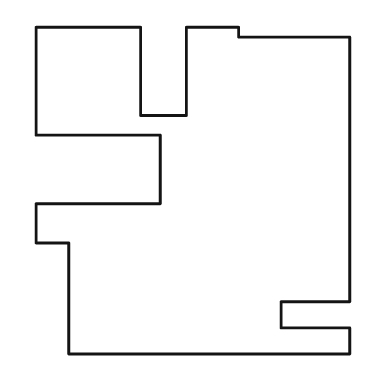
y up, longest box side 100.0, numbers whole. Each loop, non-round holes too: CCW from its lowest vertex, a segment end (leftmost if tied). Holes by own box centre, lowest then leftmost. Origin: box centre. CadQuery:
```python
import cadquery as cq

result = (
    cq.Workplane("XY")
    .moveTo(-38.0, -50.0)
    .lineTo(48.0, -50.0)
    .lineTo(48.0, -42.0)
    .lineTo(27.0, -42.0)
    .lineTo(27.0, -34.0)
    .lineTo(48.0, -34.0)
    .lineTo(48.0, 47.0)
    .lineTo(14.0, 47.0)
    .lineTo(14.0, 50.0)
    .lineTo(-2.0, 50.0)
    .lineTo(-2.0, 23.0)
    .lineTo(-16.0, 23.0)
    .lineTo(-16.0, 50.0)
    .lineTo(-48.0, 50.0)
    .lineTo(-48.0, 17.0)
    .lineTo(-10.0, 17.0)
    .lineTo(-10.0, -4.0)
    .lineTo(-48.0, -4.0)
    .lineTo(-48.0, -16.0)
    .lineTo(-38.0, -16.0)
    .close()
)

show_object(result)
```